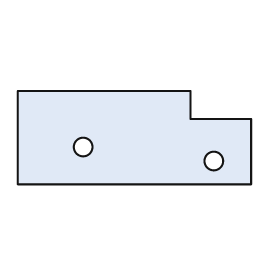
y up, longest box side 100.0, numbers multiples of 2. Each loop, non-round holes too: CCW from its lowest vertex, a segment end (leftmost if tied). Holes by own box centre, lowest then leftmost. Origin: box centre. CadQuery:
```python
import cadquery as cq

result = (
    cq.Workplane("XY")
    .moveTo(-50.0, -20.0)
    .lineTo(50.0, -20.0)
    .lineTo(50.0, 8.0)
    .lineTo(24.0, 8.0)
    .lineTo(24.0, 20.0)
    .lineTo(-50.0, 20.0)
    .close()
    .moveTo(34.0, -10.0)
    .circle(4.0)
    .moveTo(-22.0, -4.0)
    .circle(4.0)
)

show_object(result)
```